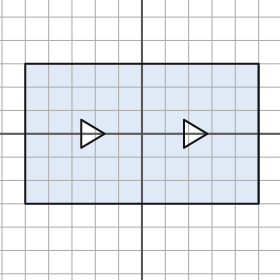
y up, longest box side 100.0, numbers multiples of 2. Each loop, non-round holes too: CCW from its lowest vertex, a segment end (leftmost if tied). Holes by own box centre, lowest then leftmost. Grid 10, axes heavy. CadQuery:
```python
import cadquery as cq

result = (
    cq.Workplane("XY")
    .moveTo(-50.0, -30.0)
    .lineTo(50.0, -30.0)
    .lineTo(50.0, 30.0)
    .lineTo(-50.0, 30.0)
    .close()
    .moveTo(-26.0, -6.0)
    .lineTo(-16.0, 0.0)
    .lineTo(-26.0, 6.0)
    .close()
    .moveTo(18.0, -6.0)
    .lineTo(28.0, 0.0)
    .lineTo(18.0, 6.0)
    .close()
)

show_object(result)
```